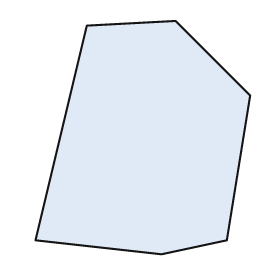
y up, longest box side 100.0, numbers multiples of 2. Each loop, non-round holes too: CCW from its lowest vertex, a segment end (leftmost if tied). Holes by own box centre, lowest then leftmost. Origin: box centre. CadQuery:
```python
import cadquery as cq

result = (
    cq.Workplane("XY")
    .moveTo(8.0, -50.0)
    .lineTo(36.0, -44.0)
    .lineTo(46.0, 18.0)
    .lineTo(14.0, 50.0)
    .lineTo(-24.0, 48.0)
    .lineTo(-46.0, -44.0)
    .close()
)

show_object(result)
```